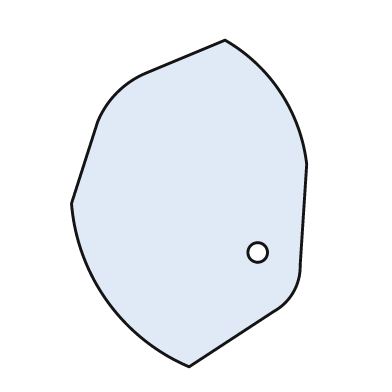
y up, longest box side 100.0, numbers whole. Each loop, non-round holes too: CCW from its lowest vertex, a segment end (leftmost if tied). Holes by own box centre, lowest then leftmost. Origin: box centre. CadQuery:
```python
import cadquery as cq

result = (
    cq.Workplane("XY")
    .moveTo(0.0, -50.0)
    .lineTo(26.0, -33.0)
    .threePointArc((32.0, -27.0), (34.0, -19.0))
    .lineTo(36.0, 12.0)
    .threePointArc((28.0, 34.0), (11.0, 50.0))
    .lineTo(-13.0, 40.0)
    .threePointArc((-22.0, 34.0), (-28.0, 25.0))
    .lineTo(-36.0, 0.0)
    .threePointArc((-25.0, -30.0), (0.0, -50.0))
    .close()
    .moveTo(21.0, -15.0)
    .circle(3.0)
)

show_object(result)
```